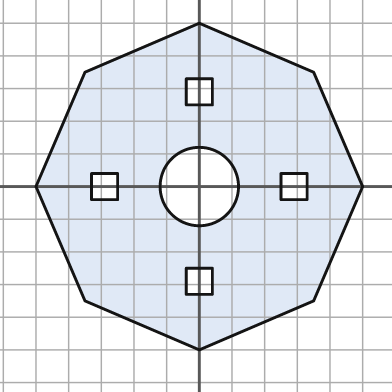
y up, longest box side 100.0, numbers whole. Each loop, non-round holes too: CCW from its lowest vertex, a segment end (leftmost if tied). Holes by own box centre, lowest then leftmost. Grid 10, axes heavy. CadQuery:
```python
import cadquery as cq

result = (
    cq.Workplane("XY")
    .moveTo(0.0, -50.0)
    .lineTo(35.0, -35.0)
    .lineTo(50.0, 0.0)
    .lineTo(35.0, 35.0)
    .lineTo(0.0, 50.0)
    .lineTo(-35.0, 35.0)
    .lineTo(-50.0, 0.0)
    .lineTo(-35.0, -35.0)
    .close()
    .moveTo(-4.0, -33.0)
    .lineTo(4.0, -33.0)
    .lineTo(4.0, -25.0)
    .lineTo(-4.0, -25.0)
    .close()
    .moveTo(-33.0, -4.0)
    .lineTo(-25.0, -4.0)
    .lineTo(-25.0, 4.0)
    .lineTo(-33.0, 4.0)
    .close()
    .moveTo(0.0, 0.0)
    .circle(12.0)
    .moveTo(25.0, -4.0)
    .lineTo(33.0, -4.0)
    .lineTo(33.0, 4.0)
    .lineTo(25.0, 4.0)
    .close()
    .moveTo(-4.0, 25.0)
    .lineTo(4.0, 25.0)
    .lineTo(4.0, 33.0)
    .lineTo(-4.0, 33.0)
    .close()
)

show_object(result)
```